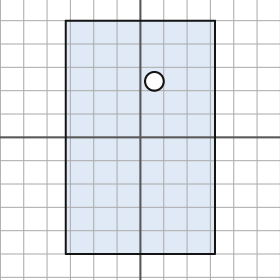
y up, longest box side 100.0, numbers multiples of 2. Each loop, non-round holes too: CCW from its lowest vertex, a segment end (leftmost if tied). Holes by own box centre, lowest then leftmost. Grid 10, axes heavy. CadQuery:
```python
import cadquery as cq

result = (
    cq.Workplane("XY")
    .moveTo(-32.0, -50.0)
    .lineTo(32.0, -50.0)
    .lineTo(32.0, 50.0)
    .lineTo(-32.0, 50.0)
    .close()
    .moveTo(6.0, 24.0)
    .circle(4.0)
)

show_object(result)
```